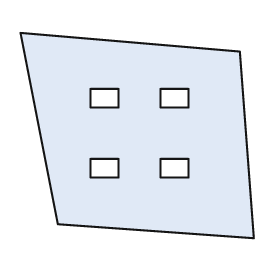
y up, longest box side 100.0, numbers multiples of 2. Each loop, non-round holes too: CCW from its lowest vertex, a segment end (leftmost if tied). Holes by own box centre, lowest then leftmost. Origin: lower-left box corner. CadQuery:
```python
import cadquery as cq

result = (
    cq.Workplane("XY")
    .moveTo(100.0, 0.0)
    .lineTo(94.0, 80.0)
    .lineTo(0.0, 88.0)
    .lineTo(16.0, 6.0)
    .close()
    .moveTo(30.0, 26.0)
    .lineTo(42.0, 26.0)
    .lineTo(42.0, 34.0)
    .lineTo(30.0, 34.0)
    .close()
    .moveTo(60.0, 26.0)
    .lineTo(72.0, 26.0)
    .lineTo(72.0, 34.0)
    .lineTo(60.0, 34.0)
    .close()
    .moveTo(30.0, 56.0)
    .lineTo(42.0, 56.0)
    .lineTo(42.0, 64.0)
    .lineTo(30.0, 64.0)
    .close()
    .moveTo(60.0, 56.0)
    .lineTo(72.0, 56.0)
    .lineTo(72.0, 64.0)
    .lineTo(60.0, 64.0)
    .close()
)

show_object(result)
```